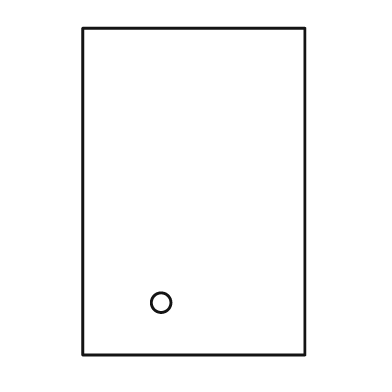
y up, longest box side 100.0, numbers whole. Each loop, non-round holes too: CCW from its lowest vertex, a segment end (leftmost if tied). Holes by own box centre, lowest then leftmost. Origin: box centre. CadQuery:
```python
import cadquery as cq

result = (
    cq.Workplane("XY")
    .moveTo(-34.0, -50.0)
    .lineTo(34.0, -50.0)
    .lineTo(34.0, 50.0)
    .lineTo(-34.0, 50.0)
    .close()
    .moveTo(-10.0, -34.0)
    .circle(3.0)
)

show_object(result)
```